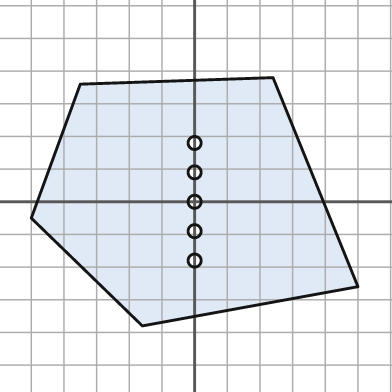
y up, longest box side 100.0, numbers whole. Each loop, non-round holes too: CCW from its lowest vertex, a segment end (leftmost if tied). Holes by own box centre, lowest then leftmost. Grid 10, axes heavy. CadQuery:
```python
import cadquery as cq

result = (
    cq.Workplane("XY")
    .moveTo(-16.0, -38.0)
    .lineTo(50.0, -26.0)
    .lineTo(24.0, 38.0)
    .lineTo(-35.0, 36.0)
    .lineTo(-50.0, -5.0)
    .close()
    .moveTo(0.0, -18.0)
    .circle(2.0)
    .moveTo(0.0, -9.0)
    .circle(2.0)
    .moveTo(0.0, 0.0)
    .circle(2.0)
    .moveTo(0.0, 9.0)
    .circle(2.0)
    .moveTo(0.0, 18.0)
    .circle(2.0)
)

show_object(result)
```